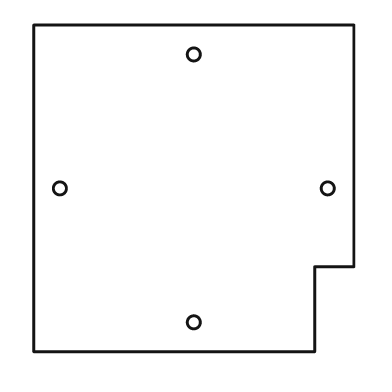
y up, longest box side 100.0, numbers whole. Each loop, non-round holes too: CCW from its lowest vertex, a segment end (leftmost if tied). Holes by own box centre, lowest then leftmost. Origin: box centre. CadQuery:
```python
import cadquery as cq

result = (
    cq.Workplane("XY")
    .moveTo(-49.0, -50.0)
    .lineTo(37.0, -50.0)
    .lineTo(37.0, -24.0)
    .lineTo(49.0, -24.0)
    .lineTo(49.0, 50.0)
    .lineTo(-49.0, 50.0)
    .close()
    .moveTo(0.0, -41.0)
    .circle(2.0)
    .moveTo(-41.0, 0.0)
    .circle(2.0)
    .moveTo(41.0, 0.0)
    .circle(2.0)
    .moveTo(0.0, 41.0)
    .circle(2.0)
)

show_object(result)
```